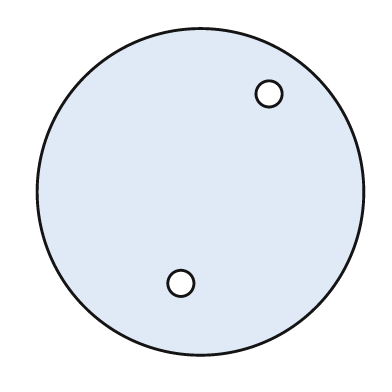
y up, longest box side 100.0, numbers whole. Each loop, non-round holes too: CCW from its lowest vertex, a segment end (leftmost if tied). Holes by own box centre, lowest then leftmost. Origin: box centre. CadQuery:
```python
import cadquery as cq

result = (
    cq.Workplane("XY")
    .moveTo(0.0, 0.0)
    .circle(50.0)
    .moveTo(-6.0, -28.0)
    .circle(4.0)
    .moveTo(21.0, 30.0)
    .circle(4.0)
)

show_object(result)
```